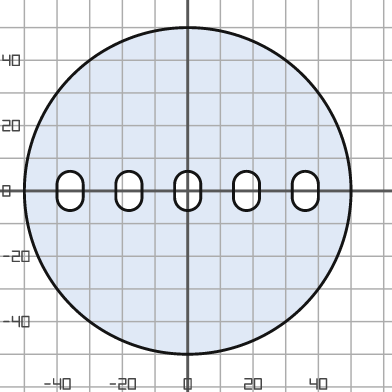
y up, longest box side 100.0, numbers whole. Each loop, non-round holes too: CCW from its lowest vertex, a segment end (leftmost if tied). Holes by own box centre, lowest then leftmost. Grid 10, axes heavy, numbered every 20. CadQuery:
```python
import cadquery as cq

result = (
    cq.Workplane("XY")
    .moveTo(0.0, 0.0)
    .circle(50.0)
    .moveTo(-40.0, -2.0)
    .threePointArc((-36.0, -6.0), (-32.0, -2.0))
    .lineTo(-32.0, 2.0)
    .threePointArc((-36.0, 6.0), (-40.0, 2.0))
    .close()
    .moveTo(-22.0, -2.0)
    .threePointArc((-18.0, -6.0), (-14.0, -2.0))
    .lineTo(-14.0, 2.0)
    .threePointArc((-18.0, 6.0), (-22.0, 2.0))
    .close()
    .moveTo(-4.0, -2.0)
    .threePointArc((0.0, -6.0), (4.0, -2.0))
    .lineTo(4.0, 2.0)
    .threePointArc((0.0, 6.0), (-4.0, 2.0))
    .close()
    .moveTo(14.0, -2.0)
    .threePointArc((18.0, -6.0), (22.0, -2.0))
    .lineTo(22.0, 2.0)
    .threePointArc((18.0, 6.0), (14.0, 2.0))
    .close()
    .moveTo(32.0, -2.0)
    .threePointArc((36.0, -6.0), (40.0, -2.0))
    .lineTo(40.0, 2.0)
    .threePointArc((36.0, 6.0), (32.0, 2.0))
    .close()
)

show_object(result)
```